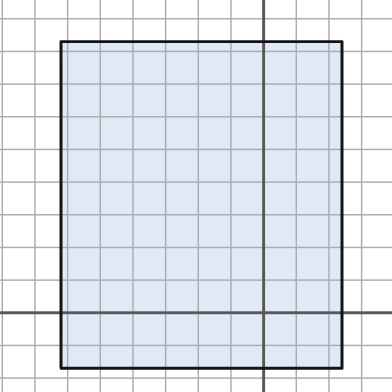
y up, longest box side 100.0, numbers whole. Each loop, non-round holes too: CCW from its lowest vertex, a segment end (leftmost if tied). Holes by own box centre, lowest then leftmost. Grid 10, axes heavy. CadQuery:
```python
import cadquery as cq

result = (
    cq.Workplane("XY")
    .moveTo(-62.0, -17.0)
    .lineTo(24.0, -17.0)
    .lineTo(24.0, 83.0)
    .lineTo(-62.0, 83.0)
    .close()
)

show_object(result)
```